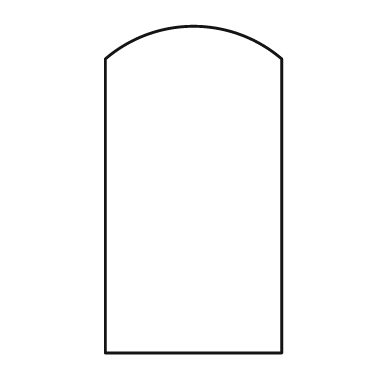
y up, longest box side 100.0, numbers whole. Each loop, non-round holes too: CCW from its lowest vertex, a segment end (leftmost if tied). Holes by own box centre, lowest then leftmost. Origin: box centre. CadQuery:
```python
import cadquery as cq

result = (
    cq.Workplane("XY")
    .moveTo(-27.0, -50.0)
    .lineTo(27.0, -50.0)
    .lineTo(27.0, 40.0)
    .threePointArc((0.0, 50.0), (-27.0, 40.0))
    .close()
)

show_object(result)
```